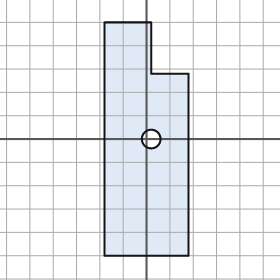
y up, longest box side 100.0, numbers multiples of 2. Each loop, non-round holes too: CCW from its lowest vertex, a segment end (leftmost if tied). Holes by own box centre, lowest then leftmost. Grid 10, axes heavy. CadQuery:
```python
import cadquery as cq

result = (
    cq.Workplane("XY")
    .moveTo(-18.0, -50.0)
    .lineTo(18.0, -50.0)
    .lineTo(18.0, 28.0)
    .lineTo(2.0, 28.0)
    .lineTo(2.0, 50.0)
    .lineTo(-18.0, 50.0)
    .close()
    .moveTo(2.0, 0.0)
    .circle(4.0)
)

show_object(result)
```